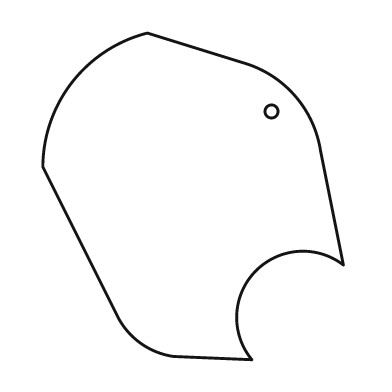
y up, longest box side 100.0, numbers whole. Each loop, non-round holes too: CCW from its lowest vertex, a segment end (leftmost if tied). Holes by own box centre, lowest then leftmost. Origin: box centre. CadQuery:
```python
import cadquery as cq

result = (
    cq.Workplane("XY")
    .moveTo(18.0, -50.0)
    .threePointArc((19.0, -23.0), (46.0, -21.0))
    .lineTo(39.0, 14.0)
    .threePointArc((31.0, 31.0), (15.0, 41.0))
    .lineTo(-14.0, 50.0)
    .threePointArc((-37.0, 35.0), (-46.0, 9.0))
    .lineTo(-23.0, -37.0)
    .threePointArc((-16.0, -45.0), (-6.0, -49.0))
    .close()
    .moveTo(24.0, 26.0)
    .circle(2.0)
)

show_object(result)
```